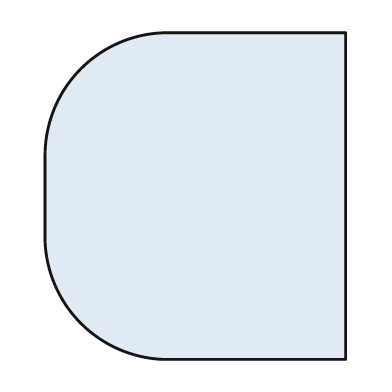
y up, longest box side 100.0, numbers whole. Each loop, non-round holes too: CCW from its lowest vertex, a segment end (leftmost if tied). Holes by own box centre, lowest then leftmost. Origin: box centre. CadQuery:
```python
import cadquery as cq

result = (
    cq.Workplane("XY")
    .moveTo(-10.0, -50.0)
    .lineTo(46.0, -50.0)
    .lineTo(46.0, 50.0)
    .lineTo(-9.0, 50.0)
    .threePointArc((-35.0, 39.0), (-46.0, 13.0))
    .lineTo(-46.0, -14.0)
    .threePointArc((-35.0, -39.0), (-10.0, -50.0))
    .close()
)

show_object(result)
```